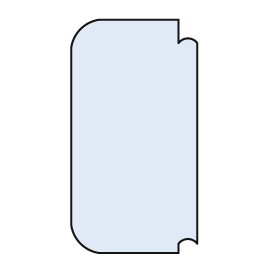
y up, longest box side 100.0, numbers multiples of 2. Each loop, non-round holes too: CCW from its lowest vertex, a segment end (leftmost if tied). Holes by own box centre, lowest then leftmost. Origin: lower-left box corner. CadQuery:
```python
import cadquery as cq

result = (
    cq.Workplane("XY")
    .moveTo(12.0, 0.0)
    .lineTo(46.0, 0.0)
    .lineTo(46.0, 4.0)
    .threePointArc((50.0, 6.0), (54.0, 4.0))
    .lineTo(54.0, 90.0)
    .threePointArc((50.0, 92.0), (46.0, 90.0))
    .lineTo(46.0, 100.0)
    .lineTo(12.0, 100.0)
    .threePointArc((4.0, 96.0), (0.0, 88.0))
    .lineTo(0.0, 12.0)
    .threePointArc((4.0, 4.0), (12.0, 0.0))
    .close()
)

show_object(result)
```